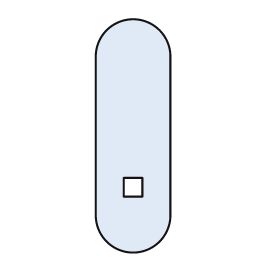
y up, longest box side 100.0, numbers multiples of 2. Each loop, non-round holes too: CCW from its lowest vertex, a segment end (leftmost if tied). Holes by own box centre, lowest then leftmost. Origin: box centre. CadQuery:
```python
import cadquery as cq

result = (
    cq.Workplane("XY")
    .moveTo(-16.0, -34.0)
    .threePointArc((0.0, -50.0), (16.0, -34.0))
    .lineTo(16.0, 34.0)
    .threePointArc((0.0, 50.0), (-16.0, 34.0))
    .close()
    .moveTo(-4.0, -26.0)
    .lineTo(4.0, -26.0)
    .lineTo(4.0, -18.0)
    .lineTo(-4.0, -18.0)
    .close()
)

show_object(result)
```